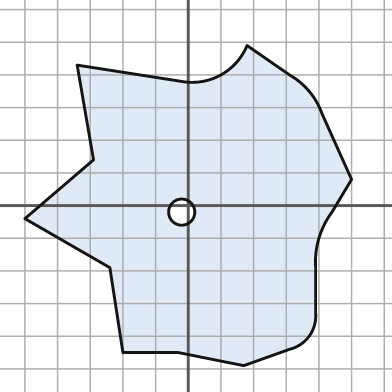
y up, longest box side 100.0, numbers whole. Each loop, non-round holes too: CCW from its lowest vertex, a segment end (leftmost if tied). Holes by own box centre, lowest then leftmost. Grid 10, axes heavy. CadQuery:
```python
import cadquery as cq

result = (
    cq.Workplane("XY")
    .moveTo(17.0, -49.0)
    .lineTo(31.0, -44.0)
    .threePointArc((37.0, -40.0), (39.0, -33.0))
    .lineTo(39.0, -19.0)
    .threePointArc((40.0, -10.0), (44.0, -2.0))
    .lineTo(50.0, 8.0)
    .lineTo(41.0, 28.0)
    .threePointArc((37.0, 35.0), (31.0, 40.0))
    .lineTo(18.0, 49.0)
    .threePointArc((10.0, 40.0), (-2.0, 38.0))
    .lineTo(-34.0, 43.0)
    .lineTo(-29.0, 14.0)
    .lineTo(-50.0, -4.0)
    .lineTo(-24.0, -19.0)
    .lineTo(-20.0, -45.0)
    .lineTo(-3.0, -45.0)
    .close()
    .moveTo(-2.0, -2.0)
    .circle(4.0)
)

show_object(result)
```